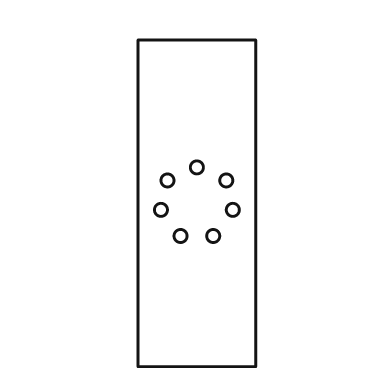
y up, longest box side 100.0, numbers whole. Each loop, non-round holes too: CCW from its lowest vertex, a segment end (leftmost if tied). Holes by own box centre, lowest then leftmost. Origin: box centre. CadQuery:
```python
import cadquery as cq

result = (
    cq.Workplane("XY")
    .moveTo(-18.0, -50.0)
    .lineTo(18.0, -50.0)
    .lineTo(18.0, 50.0)
    .lineTo(-18.0, 50.0)
    .close()
    .moveTo(-5.0, -10.0)
    .circle(2.0)
    .moveTo(5.0, -10.0)
    .circle(2.0)
    .moveTo(-11.0, -2.0)
    .circle(2.0)
    .moveTo(11.0, -2.0)
    .circle(2.0)
    .moveTo(-9.0, 7.0)
    .circle(2.0)
    .moveTo(9.0, 7.0)
    .circle(2.0)
    .moveTo(0.0, 11.0)
    .circle(2.0)
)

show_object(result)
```